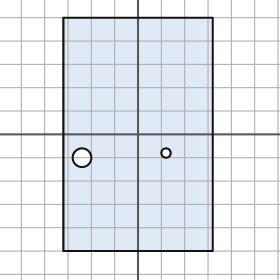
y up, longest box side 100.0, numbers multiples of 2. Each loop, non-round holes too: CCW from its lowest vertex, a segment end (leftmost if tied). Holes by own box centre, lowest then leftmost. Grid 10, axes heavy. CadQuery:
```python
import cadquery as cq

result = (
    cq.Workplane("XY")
    .moveTo(-32.0, -50.0)
    .lineTo(32.0, -50.0)
    .lineTo(32.0, 50.0)
    .lineTo(-32.0, 50.0)
    .close()
    .moveTo(-24.0, -10.0)
    .circle(4.0)
    .moveTo(12.0, -8.0)
    .circle(2.0)
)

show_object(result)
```